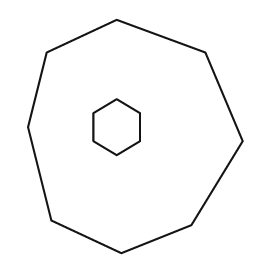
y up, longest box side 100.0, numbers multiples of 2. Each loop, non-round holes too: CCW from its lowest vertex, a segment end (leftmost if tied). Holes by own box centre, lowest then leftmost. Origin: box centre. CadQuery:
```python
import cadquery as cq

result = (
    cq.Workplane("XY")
    .moveTo(-6.0, -50.0)
    .lineTo(24.0, -38.0)
    .lineTo(46.0, -2.0)
    .lineTo(30.0, 36.0)
    .lineTo(-8.0, 50.0)
    .lineTo(-38.0, 36.0)
    .lineTo(-46.0, 4.0)
    .lineTo(-36.0, -36.0)
    .close()
    .moveTo(-8.0, -8.0)
    .lineTo(2.0, -2.0)
    .lineTo(2.0, 10.0)
    .lineTo(-8.0, 16.0)
    .lineTo(-18.0, 10.0)
    .lineTo(-18.0, -2.0)
    .close()
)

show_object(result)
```